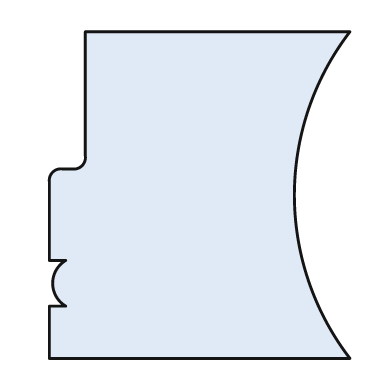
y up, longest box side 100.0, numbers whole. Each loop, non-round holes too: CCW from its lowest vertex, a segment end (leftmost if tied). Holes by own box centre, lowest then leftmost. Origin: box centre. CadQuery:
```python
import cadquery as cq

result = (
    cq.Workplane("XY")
    .moveTo(-46.0, -50.0)
    .lineTo(46.0, -50.0)
    .threePointArc((29.0, 0.0), (46.0, 50.0))
    .lineTo(-35.0, 50.0)
    .lineTo(-35.0, 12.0)
    .threePointArc((-36.0, 9.0), (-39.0, 8.0))
    .lineTo(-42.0, 8.0)
    .threePointArc((-45.0, 7.0), (-46.0, 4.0))
    .lineTo(-46.0, -20.0)
    .lineTo(-41.0, -20.0)
    .threePointArc((-45.0, -27.0), (-41.0, -34.0))
    .lineTo(-46.0, -34.0)
    .close()
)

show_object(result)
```